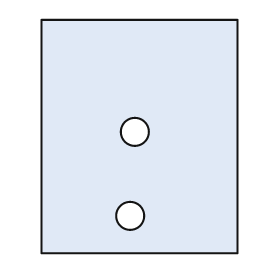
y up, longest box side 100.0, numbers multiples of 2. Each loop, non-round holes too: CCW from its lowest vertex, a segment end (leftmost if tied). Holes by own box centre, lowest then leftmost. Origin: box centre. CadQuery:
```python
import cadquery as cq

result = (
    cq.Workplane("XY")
    .moveTo(-42.0, -50.0)
    .lineTo(42.0, -50.0)
    .lineTo(42.0, 50.0)
    .lineTo(-42.0, 50.0)
    .close()
    .moveTo(-4.0, -34.0)
    .circle(6.0)
    .moveTo(-2.0, 2.0)
    .circle(6.0)
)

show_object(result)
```